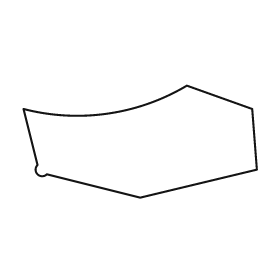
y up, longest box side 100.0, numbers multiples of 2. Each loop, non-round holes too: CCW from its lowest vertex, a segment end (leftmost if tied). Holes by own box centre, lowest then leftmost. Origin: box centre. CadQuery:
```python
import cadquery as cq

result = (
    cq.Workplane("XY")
    .moveTo(0.0, -24.0)
    .lineTo(50.0, -12.0)
    .lineTo(48.0, 14.0)
    .lineTo(20.0, 24.0)
    .threePointArc((-14.0, 12.0), (-50.0, 14.0))
    .lineTo(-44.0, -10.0)
    .threePointArc((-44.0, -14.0), (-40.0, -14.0))
    .close()
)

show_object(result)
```